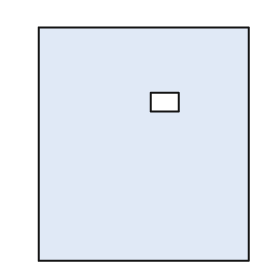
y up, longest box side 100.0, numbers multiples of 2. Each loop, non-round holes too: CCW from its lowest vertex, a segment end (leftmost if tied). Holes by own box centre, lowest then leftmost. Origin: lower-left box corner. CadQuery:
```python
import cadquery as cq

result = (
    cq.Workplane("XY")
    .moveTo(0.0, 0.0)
    .lineTo(90.0, 0.0)
    .lineTo(90.0, 100.0)
    .lineTo(0.0, 100.0)
    .close()
    .moveTo(48.0, 64.0)
    .lineTo(60.0, 64.0)
    .lineTo(60.0, 72.0)
    .lineTo(48.0, 72.0)
    .close()
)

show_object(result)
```